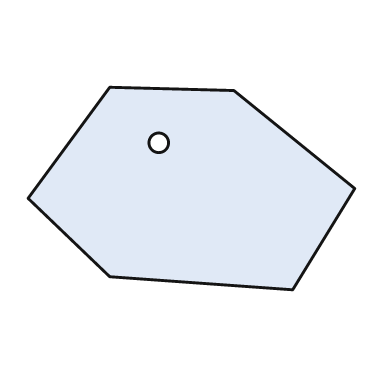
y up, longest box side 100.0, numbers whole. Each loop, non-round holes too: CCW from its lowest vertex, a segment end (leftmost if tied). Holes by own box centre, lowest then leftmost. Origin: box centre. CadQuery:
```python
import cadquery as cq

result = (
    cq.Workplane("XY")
    .moveTo(31.0, -31.0)
    .lineTo(50.0, 0.0)
    .lineTo(13.0, 30.0)
    .lineTo(-25.0, 31.0)
    .lineTo(-50.0, -3.0)
    .lineTo(-25.0, -27.0)
    .close()
    .moveTo(-10.0, 14.0)
    .circle(3.0)
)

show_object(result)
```